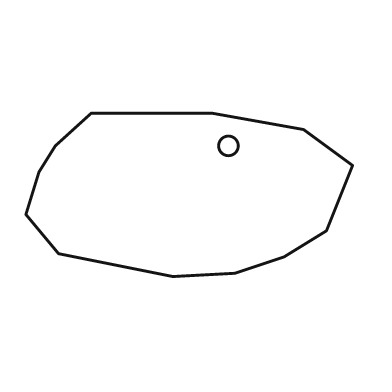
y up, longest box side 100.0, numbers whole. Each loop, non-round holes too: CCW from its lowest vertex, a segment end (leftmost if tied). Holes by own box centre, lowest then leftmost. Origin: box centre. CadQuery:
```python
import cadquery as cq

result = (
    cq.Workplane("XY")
    .moveTo(-5.0, -25.0)
    .lineTo(14.0, -24.0)
    .lineTo(29.0, -19.0)
    .lineTo(42.0, -11.0)
    .lineTo(50.0, 9.0)
    .lineTo(35.0, 20.0)
    .lineTo(7.0, 25.0)
    .lineTo(-30.0, 25.0)
    .lineTo(-41.0, 15.0)
    .lineTo(-46.0, 7.0)
    .lineTo(-50.0, -6.0)
    .lineTo(-40.0, -18.0)
    .close()
    .moveTo(12.0, 15.0)
    .circle(3.0)
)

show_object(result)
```